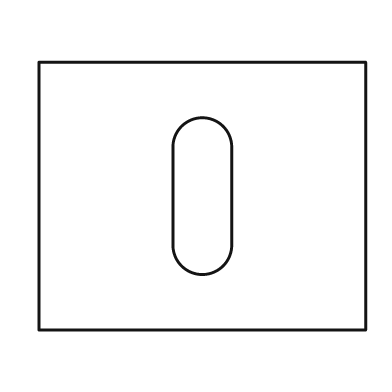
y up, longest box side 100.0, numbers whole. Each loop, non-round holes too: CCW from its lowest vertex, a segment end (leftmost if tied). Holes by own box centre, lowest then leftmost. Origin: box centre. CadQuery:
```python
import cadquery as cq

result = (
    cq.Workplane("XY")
    .moveTo(-50.0, -41.0)
    .lineTo(50.0, -41.0)
    .lineTo(50.0, 41.0)
    .lineTo(-50.0, 41.0)
    .close()
    .moveTo(-9.0, -15.0)
    .threePointArc((0.0, -24.0), (9.0, -15.0))
    .lineTo(9.0, 15.0)
    .threePointArc((0.0, 24.0), (-9.0, 15.0))
    .close()
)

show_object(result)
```